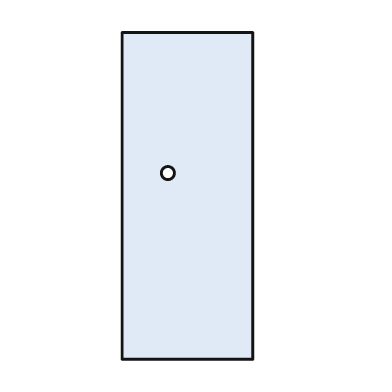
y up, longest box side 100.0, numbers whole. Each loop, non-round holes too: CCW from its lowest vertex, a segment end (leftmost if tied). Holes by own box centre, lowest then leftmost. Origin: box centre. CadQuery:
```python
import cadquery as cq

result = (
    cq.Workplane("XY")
    .moveTo(-20.0, -50.0)
    .lineTo(20.0, -50.0)
    .lineTo(20.0, 50.0)
    .lineTo(-20.0, 50.0)
    .close()
    .moveTo(-6.0, 7.0)
    .circle(2.0)
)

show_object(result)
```